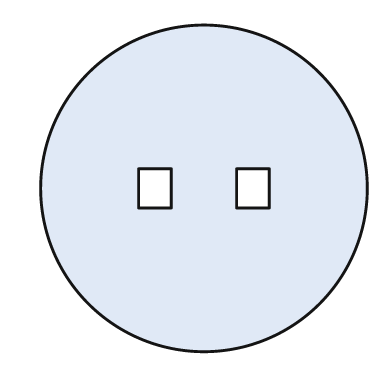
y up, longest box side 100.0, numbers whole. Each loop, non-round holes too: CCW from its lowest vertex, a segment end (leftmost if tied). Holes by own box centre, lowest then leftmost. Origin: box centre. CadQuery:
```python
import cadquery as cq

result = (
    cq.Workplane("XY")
    .moveTo(0.0, 0.0)
    .circle(50.0)
    .moveTo(-20.0, -6.0)
    .lineTo(-10.0, -6.0)
    .lineTo(-10.0, 6.0)
    .lineTo(-20.0, 6.0)
    .close()
    .moveTo(10.0, -6.0)
    .lineTo(20.0, -6.0)
    .lineTo(20.0, 6.0)
    .lineTo(10.0, 6.0)
    .close()
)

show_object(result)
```